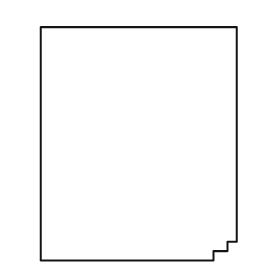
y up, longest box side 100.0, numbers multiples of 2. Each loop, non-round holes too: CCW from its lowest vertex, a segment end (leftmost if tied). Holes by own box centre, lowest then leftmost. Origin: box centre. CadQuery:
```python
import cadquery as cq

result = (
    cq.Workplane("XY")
    .moveTo(-42.0, -50.0)
    .lineTo(32.0, -50.0)
    .lineTo(32.0, -46.0)
    .lineTo(38.0, -46.0)
    .lineTo(38.0, -42.0)
    .lineTo(42.0, -42.0)
    .lineTo(42.0, 50.0)
    .lineTo(-42.0, 50.0)
    .close()
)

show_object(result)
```